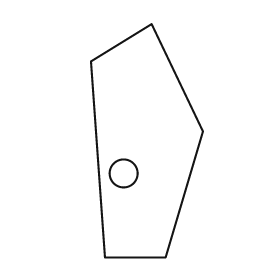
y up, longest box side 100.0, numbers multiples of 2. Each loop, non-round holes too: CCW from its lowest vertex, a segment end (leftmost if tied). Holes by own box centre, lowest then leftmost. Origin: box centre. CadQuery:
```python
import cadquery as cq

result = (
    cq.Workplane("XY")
    .moveTo(-18.0, -50.0)
    .lineTo(8.0, -50.0)
    .lineTo(24.0, 4.0)
    .lineTo(2.0, 50.0)
    .lineTo(-24.0, 34.0)
    .close()
    .moveTo(-10.0, -14.0)
    .circle(6.0)
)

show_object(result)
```